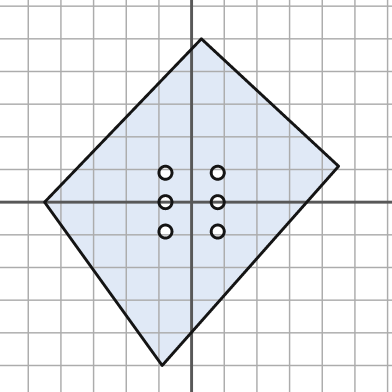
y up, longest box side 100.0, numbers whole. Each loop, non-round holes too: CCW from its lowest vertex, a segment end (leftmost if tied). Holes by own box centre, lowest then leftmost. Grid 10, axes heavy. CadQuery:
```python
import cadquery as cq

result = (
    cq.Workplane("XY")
    .moveTo(-9.0, -50.0)
    .lineTo(45.0, 11.0)
    .lineTo(3.0, 50.0)
    .lineTo(-45.0, 0.0)
    .close()
    .moveTo(-8.0, -9.0)
    .circle(2.0)
    .moveTo(8.0, -9.0)
    .circle(2.0)
    .moveTo(-8.0, 0.0)
    .circle(2.0)
    .moveTo(8.0, 0.0)
    .circle(2.0)
    .moveTo(-8.0, 9.0)
    .circle(2.0)
    .moveTo(8.0, 9.0)
    .circle(2.0)
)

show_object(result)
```